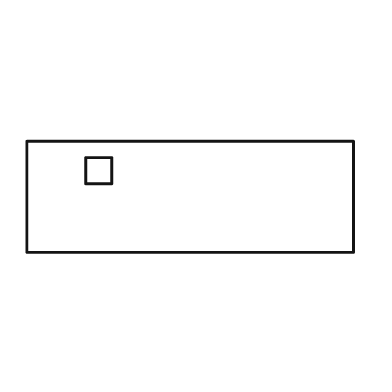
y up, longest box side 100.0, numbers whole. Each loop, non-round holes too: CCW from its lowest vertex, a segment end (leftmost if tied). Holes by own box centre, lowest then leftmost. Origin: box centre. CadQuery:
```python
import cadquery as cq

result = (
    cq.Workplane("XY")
    .moveTo(-50.0, -17.0)
    .lineTo(50.0, -17.0)
    .lineTo(50.0, 17.0)
    .lineTo(-50.0, 17.0)
    .close()
    .moveTo(-32.0, 4.0)
    .lineTo(-24.0, 4.0)
    .lineTo(-24.0, 12.0)
    .lineTo(-32.0, 12.0)
    .close()
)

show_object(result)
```